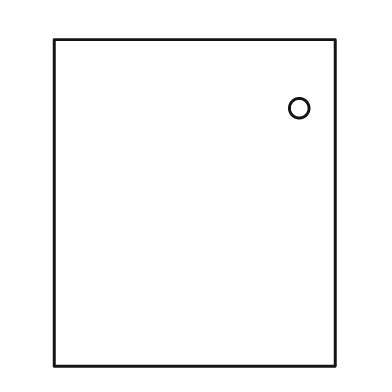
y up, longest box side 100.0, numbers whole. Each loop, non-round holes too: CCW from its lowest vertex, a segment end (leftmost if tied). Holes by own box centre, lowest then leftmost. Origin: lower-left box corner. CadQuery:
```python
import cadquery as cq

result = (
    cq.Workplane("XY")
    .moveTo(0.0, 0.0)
    .lineTo(86.0, 0.0)
    .lineTo(86.0, 100.0)
    .lineTo(0.0, 100.0)
    .close()
    .moveTo(75.0, 79.0)
    .circle(3.0)
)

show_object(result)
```